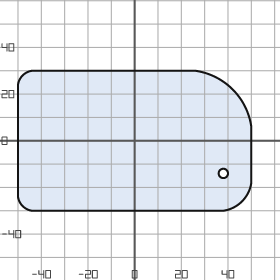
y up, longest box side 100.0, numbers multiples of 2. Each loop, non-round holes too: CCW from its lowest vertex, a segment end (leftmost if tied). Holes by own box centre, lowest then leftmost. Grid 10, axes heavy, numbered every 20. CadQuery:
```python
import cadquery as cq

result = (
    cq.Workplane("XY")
    .moveTo(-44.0, -30.0)
    .lineTo(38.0, -30.0)
    .threePointArc((46.0, -26.0), (50.0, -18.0))
    .lineTo(50.0, 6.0)
    .threePointArc((42.0, 22.0), (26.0, 30.0))
    .lineTo(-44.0, 30.0)
    .threePointArc((-48.0, 28.0), (-50.0, 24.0))
    .lineTo(-50.0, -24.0)
    .threePointArc((-48.0, -28.0), (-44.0, -30.0))
    .close()
    .moveTo(38.0, -14.0)
    .circle(2.0)
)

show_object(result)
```